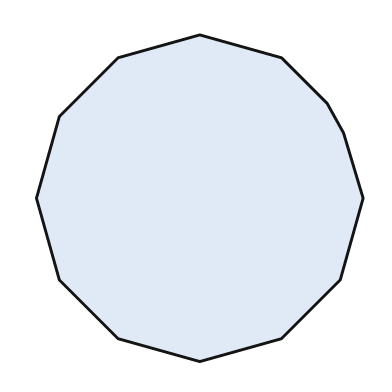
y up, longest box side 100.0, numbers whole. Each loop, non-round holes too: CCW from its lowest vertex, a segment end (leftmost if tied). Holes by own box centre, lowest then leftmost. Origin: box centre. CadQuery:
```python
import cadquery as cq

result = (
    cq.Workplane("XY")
    .moveTo(0.0, -50.0)
    .lineTo(25.0, -43.0)
    .lineTo(43.0, -25.0)
    .lineTo(50.0, 0.0)
    .lineTo(44.0, 20.0)
    .lineTo(39.0, 29.0)
    .lineTo(25.0, 43.0)
    .lineTo(0.0, 50.0)
    .lineTo(-25.0, 43.0)
    .lineTo(-43.0, 25.0)
    .lineTo(-50.0, 0.0)
    .lineTo(-43.0, -25.0)
    .lineTo(-25.0, -43.0)
    .close()
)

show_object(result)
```